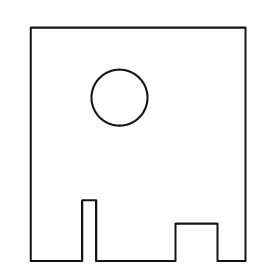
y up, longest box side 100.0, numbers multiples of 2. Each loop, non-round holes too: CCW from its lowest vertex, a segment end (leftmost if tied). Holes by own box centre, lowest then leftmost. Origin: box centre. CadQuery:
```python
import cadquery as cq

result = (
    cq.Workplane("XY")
    .moveTo(-46.0, -50.0)
    .lineTo(-24.0, -50.0)
    .lineTo(-24.0, -24.0)
    .lineTo(-18.0, -24.0)
    .lineTo(-18.0, -50.0)
    .lineTo(16.0, -50.0)
    .lineTo(16.0, -34.0)
    .lineTo(34.0, -34.0)
    .lineTo(34.0, -50.0)
    .lineTo(46.0, -50.0)
    .lineTo(46.0, 50.0)
    .lineTo(-46.0, 50.0)
    .close()
    .moveTo(-8.0, 20.0)
    .circle(12.0)
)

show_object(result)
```